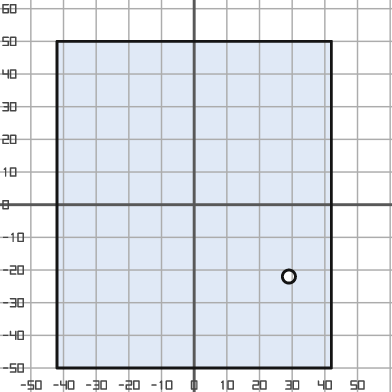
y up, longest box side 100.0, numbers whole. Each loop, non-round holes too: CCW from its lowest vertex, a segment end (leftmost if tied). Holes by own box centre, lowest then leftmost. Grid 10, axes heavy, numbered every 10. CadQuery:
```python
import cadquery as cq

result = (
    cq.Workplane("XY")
    .moveTo(-42.0, -50.0)
    .lineTo(42.0, -50.0)
    .lineTo(42.0, 50.0)
    .lineTo(-42.0, 50.0)
    .close()
    .moveTo(29.0, -22.0)
    .circle(2.0)
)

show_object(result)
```